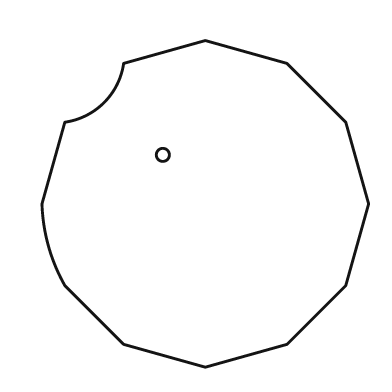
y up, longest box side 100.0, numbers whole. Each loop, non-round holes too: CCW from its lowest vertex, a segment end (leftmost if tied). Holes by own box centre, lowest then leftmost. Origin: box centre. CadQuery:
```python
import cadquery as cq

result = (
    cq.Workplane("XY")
    .moveTo(0.0, -50.0)
    .lineTo(25.0, -43.0)
    .lineTo(43.0, -25.0)
    .lineTo(50.0, 0.0)
    .lineTo(43.0, 25.0)
    .lineTo(25.0, 43.0)
    .lineTo(0.0, 50.0)
    .lineTo(-25.0, 43.0)
    .threePointArc((-31.0, 31.0), (-43.0, 25.0))
    .lineTo(-50.0, 0.0)
    .threePointArc((-48.0, -13.0), (-43.0, -25.0))
    .lineTo(-25.0, -43.0)
    .close()
    .moveTo(-13.0, 15.0)
    .circle(2.0)
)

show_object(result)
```